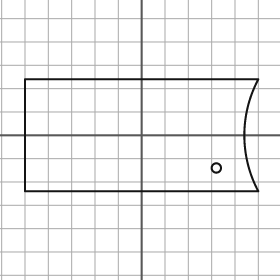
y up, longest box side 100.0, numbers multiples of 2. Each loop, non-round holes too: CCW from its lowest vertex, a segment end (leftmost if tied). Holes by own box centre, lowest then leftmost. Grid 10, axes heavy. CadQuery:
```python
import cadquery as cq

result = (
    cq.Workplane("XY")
    .moveTo(-50.0, -24.0)
    .lineTo(50.0, -24.0)
    .threePointArc((44.0, 0.0), (50.0, 24.0))
    .lineTo(-50.0, 24.0)
    .close()
    .moveTo(32.0, -14.0)
    .circle(2.0)
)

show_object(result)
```